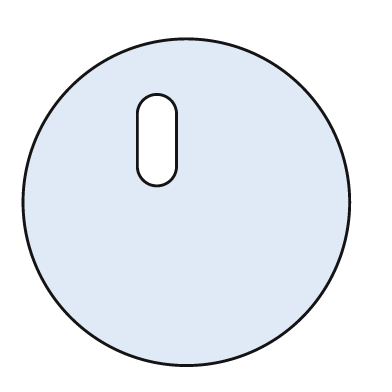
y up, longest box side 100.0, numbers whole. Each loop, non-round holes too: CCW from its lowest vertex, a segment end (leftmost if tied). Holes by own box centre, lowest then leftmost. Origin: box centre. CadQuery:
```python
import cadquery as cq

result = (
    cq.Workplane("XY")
    .moveTo(0.0, 0.0)
    .circle(50.0)
    .moveTo(-15.0, 11.0)
    .threePointArc((-9.0, 5.0), (-3.0, 11.0))
    .lineTo(-3.0, 27.0)
    .threePointArc((-9.0, 33.0), (-15.0, 27.0))
    .close()
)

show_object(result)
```